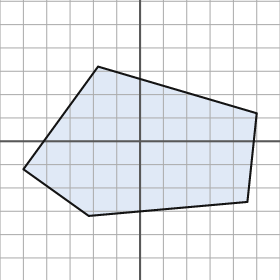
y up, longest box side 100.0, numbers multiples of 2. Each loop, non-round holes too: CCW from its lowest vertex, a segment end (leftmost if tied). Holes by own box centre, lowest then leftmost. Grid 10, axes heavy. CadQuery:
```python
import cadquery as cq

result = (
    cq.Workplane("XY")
    .moveTo(-22.0, -32.0)
    .lineTo(46.0, -26.0)
    .lineTo(50.0, 12.0)
    .lineTo(-18.0, 32.0)
    .lineTo(-50.0, -12.0)
    .close()
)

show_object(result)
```